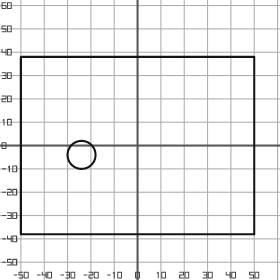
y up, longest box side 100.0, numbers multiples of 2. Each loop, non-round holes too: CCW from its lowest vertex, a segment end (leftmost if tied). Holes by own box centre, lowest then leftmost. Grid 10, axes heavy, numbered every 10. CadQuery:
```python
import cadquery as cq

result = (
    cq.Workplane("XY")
    .moveTo(-50.0, -38.0)
    .lineTo(50.0, -38.0)
    .lineTo(50.0, 38.0)
    .lineTo(-50.0, 38.0)
    .close()
    .moveTo(-24.0, -4.0)
    .circle(6.0)
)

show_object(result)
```